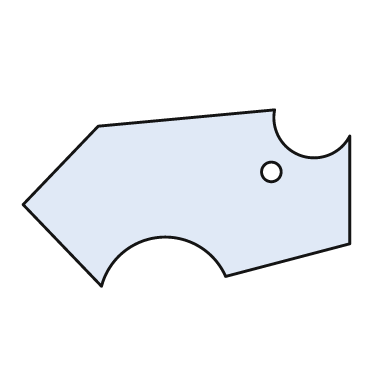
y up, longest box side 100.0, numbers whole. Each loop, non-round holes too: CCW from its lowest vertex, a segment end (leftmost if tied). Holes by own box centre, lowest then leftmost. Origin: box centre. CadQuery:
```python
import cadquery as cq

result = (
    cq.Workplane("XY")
    .moveTo(-26.0, -27.0)
    .threePointArc((-8.0, -12.0), (12.0, -24.0))
    .lineTo(50.0, -14.0)
    .lineTo(50.0, 19.0)
    .threePointArc((35.0, 13.0), (27.0, 27.0))
    .lineTo(-27.0, 22.0)
    .lineTo(-50.0, -2.0)
    .close()
    .moveTo(26.0, 8.0)
    .circle(3.0)
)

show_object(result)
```